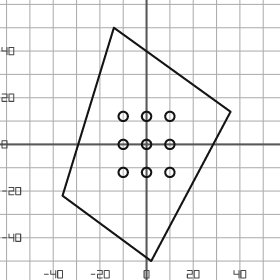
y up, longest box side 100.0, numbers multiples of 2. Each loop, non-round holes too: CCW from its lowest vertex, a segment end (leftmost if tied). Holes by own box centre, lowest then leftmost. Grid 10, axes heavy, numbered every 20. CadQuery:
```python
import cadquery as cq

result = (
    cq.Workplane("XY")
    .moveTo(2.0, -50.0)
    .lineTo(36.0, 14.0)
    .lineTo(-14.0, 50.0)
    .lineTo(-36.0, -22.0)
    .close()
    .moveTo(-10.0, -12.0)
    .circle(2.0)
    .moveTo(0.0, -12.0)
    .circle(2.0)
    .moveTo(10.0, -12.0)
    .circle(2.0)
    .moveTo(-10.0, 0.0)
    .circle(2.0)
    .moveTo(0.0, 0.0)
    .circle(2.0)
    .moveTo(10.0, 0.0)
    .circle(2.0)
    .moveTo(-10.0, 12.0)
    .circle(2.0)
    .moveTo(0.0, 12.0)
    .circle(2.0)
    .moveTo(10.0, 12.0)
    .circle(2.0)
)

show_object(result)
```